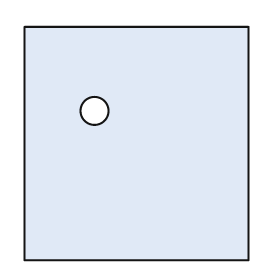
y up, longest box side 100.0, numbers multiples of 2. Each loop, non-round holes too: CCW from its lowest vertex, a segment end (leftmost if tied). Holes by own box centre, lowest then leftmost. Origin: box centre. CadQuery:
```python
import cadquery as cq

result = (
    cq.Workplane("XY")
    .moveTo(-48.0, -50.0)
    .lineTo(48.0, -50.0)
    .lineTo(48.0, 50.0)
    .lineTo(-48.0, 50.0)
    .close()
    .moveTo(-18.0, 14.0)
    .circle(6.0)
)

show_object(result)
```